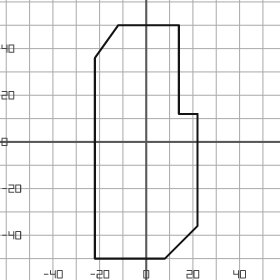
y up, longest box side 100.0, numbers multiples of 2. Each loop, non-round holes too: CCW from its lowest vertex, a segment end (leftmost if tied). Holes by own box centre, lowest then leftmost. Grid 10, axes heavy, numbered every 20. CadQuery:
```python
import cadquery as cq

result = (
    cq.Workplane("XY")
    .moveTo(-22.0, -50.0)
    .lineTo(8.0, -50.0)
    .lineTo(22.0, -36.0)
    .lineTo(22.0, 12.0)
    .lineTo(14.0, 12.0)
    .lineTo(14.0, 50.0)
    .lineTo(-12.0, 50.0)
    .lineTo(-22.0, 36.0)
    .close()
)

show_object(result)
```